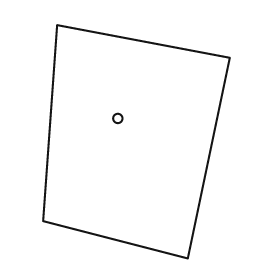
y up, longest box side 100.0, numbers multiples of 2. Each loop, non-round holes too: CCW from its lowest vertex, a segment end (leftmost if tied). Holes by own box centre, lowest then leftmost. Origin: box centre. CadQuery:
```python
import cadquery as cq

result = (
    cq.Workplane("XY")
    .moveTo(22.0, -50.0)
    .lineTo(40.0, 36.0)
    .lineTo(-34.0, 50.0)
    .lineTo(-40.0, -34.0)
    .close()
    .moveTo(-8.0, 10.0)
    .circle(2.0)
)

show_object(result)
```